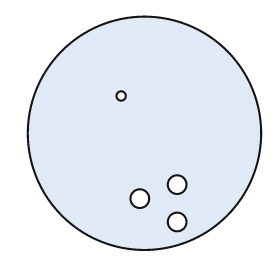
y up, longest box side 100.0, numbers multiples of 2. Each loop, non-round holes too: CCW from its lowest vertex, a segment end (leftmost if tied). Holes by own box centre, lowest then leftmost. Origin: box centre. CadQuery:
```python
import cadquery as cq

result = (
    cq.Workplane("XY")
    .moveTo(0.0, 0.0)
    .circle(50.0)
    .moveTo(14.0, -38.0)
    .circle(4.0)
    .moveTo(-2.0, -28.0)
    .circle(4.0)
    .moveTo(14.0, -22.0)
    .circle(4.0)
    .moveTo(-10.0, 16.0)
    .circle(2.0)
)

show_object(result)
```